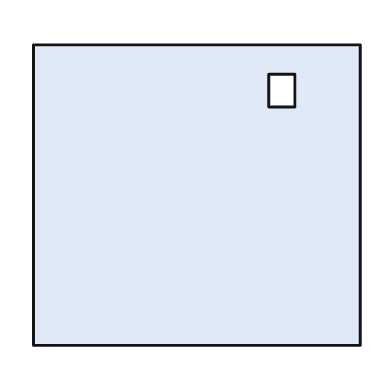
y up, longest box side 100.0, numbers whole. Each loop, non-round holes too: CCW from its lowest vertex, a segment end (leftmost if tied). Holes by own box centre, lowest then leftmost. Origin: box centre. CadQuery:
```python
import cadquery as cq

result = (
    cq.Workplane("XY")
    .moveTo(-50.0, -46.0)
    .lineTo(50.0, -46.0)
    .lineTo(50.0, 46.0)
    .lineTo(-50.0, 46.0)
    .close()
    .moveTo(22.0, 27.0)
    .lineTo(30.0, 27.0)
    .lineTo(30.0, 37.0)
    .lineTo(22.0, 37.0)
    .close()
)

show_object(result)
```